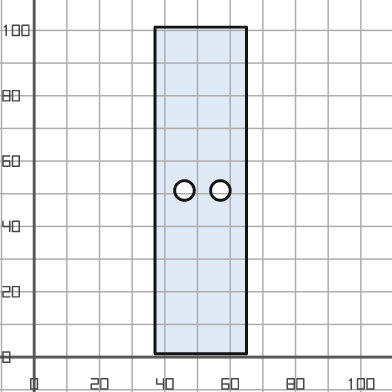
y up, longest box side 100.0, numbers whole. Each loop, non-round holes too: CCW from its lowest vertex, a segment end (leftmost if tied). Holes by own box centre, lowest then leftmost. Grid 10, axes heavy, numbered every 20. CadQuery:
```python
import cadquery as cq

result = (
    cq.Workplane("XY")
    .moveTo(37.0, 1.0)
    .lineTo(65.0, 1.0)
    .lineTo(65.0, 101.0)
    .lineTo(37.0, 101.0)
    .close()
    .moveTo(46.0, 51.0)
    .circle(3.0)
    .moveTo(57.0, 51.0)
    .circle(3.0)
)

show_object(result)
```